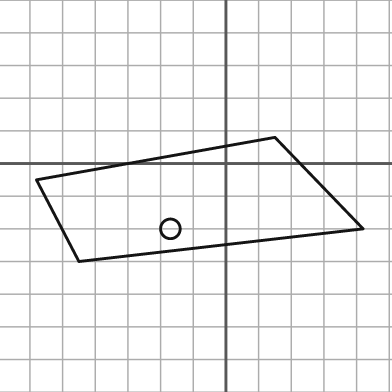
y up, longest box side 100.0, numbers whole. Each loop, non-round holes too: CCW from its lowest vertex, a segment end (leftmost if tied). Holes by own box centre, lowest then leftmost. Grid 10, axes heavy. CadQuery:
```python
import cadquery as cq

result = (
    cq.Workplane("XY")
    .moveTo(-45.0, -30.0)
    .lineTo(42.0, -20.0)
    .lineTo(15.0, 8.0)
    .lineTo(-58.0, -5.0)
    .close()
    .moveTo(-17.0, -20.0)
    .circle(3.0)
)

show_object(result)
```